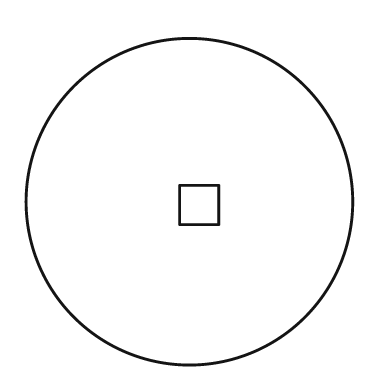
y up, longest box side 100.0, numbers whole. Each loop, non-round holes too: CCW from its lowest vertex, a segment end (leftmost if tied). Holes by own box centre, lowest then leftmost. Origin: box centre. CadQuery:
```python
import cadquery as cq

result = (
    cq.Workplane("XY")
    .moveTo(0.0, 0.0)
    .circle(50.0)
    .moveTo(-3.0, -7.0)
    .lineTo(9.0, -7.0)
    .lineTo(9.0, 5.0)
    .lineTo(-3.0, 5.0)
    .close()
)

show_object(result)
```